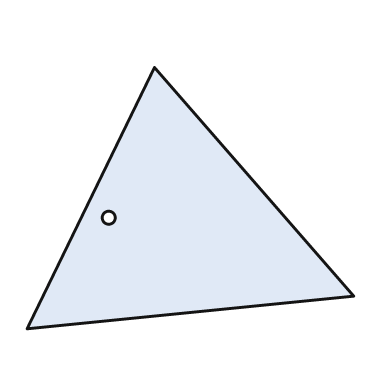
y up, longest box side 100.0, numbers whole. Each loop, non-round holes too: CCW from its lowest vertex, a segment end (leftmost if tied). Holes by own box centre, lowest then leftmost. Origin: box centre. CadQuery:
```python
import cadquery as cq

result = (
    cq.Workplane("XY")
    .moveTo(-50.0, -40.0)
    .lineTo(50.0, -30.0)
    .lineTo(-11.0, 40.0)
    .close()
    .moveTo(-25.0, -6.0)
    .circle(2.0)
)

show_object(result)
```